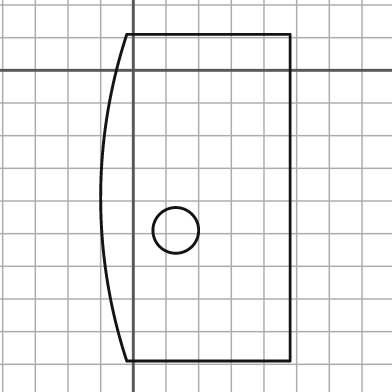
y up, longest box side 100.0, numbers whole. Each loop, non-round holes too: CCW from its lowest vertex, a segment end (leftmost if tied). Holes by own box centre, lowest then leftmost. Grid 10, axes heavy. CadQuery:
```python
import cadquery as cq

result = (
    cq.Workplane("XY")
    .moveTo(-2.0, -89.0)
    .lineTo(48.0, -89.0)
    .lineTo(48.0, 11.0)
    .lineTo(-2.0, 11.0)
    .threePointArc((-10.0, -39.0), (-2.0, -89.0))
    .close()
    .moveTo(13.0, -49.0)
    .circle(7.0)
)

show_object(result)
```